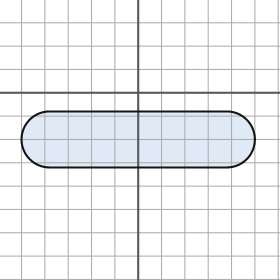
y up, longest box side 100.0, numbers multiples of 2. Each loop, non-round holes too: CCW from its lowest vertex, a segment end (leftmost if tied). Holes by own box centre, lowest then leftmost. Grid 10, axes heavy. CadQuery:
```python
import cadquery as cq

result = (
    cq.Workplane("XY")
    .moveTo(-38.0, -32.0)
    .lineTo(38.0, -32.0)
    .threePointArc((50.0, -20.0), (38.0, -8.0))
    .lineTo(-38.0, -8.0)
    .threePointArc((-50.0, -20.0), (-38.0, -32.0))
    .close()
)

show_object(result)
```